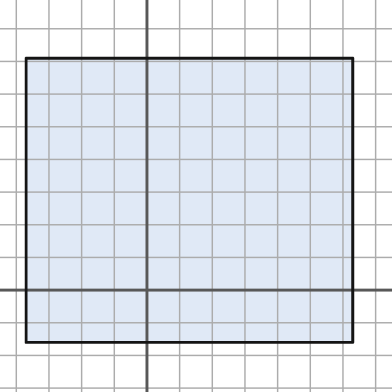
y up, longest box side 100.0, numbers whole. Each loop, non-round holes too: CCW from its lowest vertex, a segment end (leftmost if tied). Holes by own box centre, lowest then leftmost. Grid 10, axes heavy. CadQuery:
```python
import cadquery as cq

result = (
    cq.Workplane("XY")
    .moveTo(-37.0, -16.0)
    .lineTo(63.0, -16.0)
    .lineTo(63.0, 71.0)
    .lineTo(-37.0, 71.0)
    .close()
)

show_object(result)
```